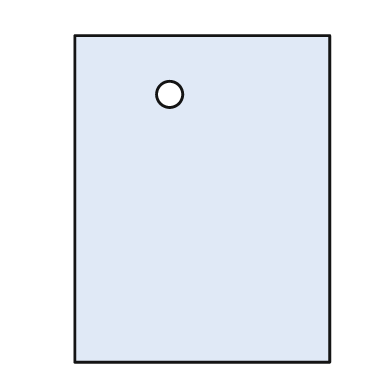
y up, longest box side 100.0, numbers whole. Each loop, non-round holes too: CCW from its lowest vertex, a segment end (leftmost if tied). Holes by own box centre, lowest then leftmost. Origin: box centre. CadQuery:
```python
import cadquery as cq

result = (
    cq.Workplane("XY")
    .moveTo(-39.0, -50.0)
    .lineTo(39.0, -50.0)
    .lineTo(39.0, 50.0)
    .lineTo(-39.0, 50.0)
    .close()
    .moveTo(-10.0, 32.0)
    .circle(4.0)
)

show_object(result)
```